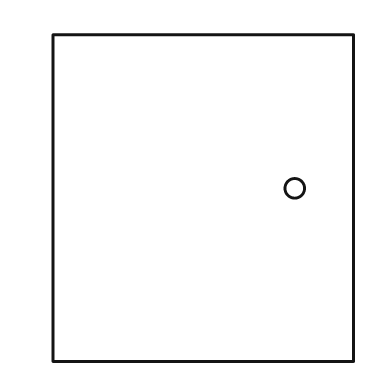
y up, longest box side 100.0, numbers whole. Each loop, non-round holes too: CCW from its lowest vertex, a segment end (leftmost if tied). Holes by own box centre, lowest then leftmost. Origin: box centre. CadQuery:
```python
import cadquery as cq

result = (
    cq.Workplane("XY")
    .moveTo(-46.0, -50.0)
    .lineTo(46.0, -50.0)
    .lineTo(46.0, 50.0)
    .lineTo(-46.0, 50.0)
    .close()
    .moveTo(28.0, 3.0)
    .circle(3.0)
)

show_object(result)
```